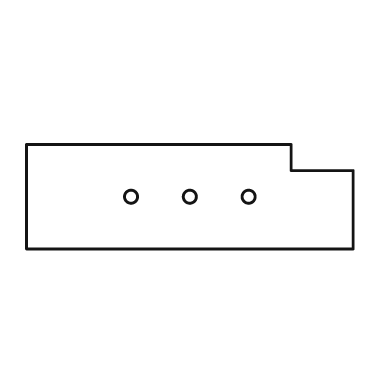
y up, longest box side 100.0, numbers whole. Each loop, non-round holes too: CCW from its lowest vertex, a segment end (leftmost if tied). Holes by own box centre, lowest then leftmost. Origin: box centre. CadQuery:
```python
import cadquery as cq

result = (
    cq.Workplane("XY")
    .moveTo(-50.0, -16.0)
    .lineTo(50.0, -16.0)
    .lineTo(50.0, 8.0)
    .lineTo(31.0, 8.0)
    .lineTo(31.0, 16.0)
    .lineTo(-50.0, 16.0)
    .close()
    .moveTo(-18.0, 0.0)
    .circle(2.0)
    .moveTo(0.0, 0.0)
    .circle(2.0)
    .moveTo(18.0, 0.0)
    .circle(2.0)
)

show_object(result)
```